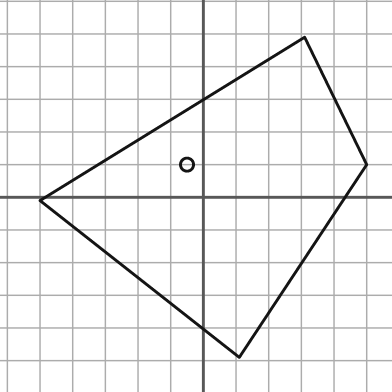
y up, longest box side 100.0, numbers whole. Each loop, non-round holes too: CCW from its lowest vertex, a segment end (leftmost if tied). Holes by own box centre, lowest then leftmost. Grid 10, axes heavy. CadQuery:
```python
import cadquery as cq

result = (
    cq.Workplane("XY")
    .moveTo(11.0, -49.0)
    .lineTo(50.0, 10.0)
    .lineTo(31.0, 49.0)
    .lineTo(-50.0, -1.0)
    .close()
    .moveTo(-5.0, 10.0)
    .circle(2.0)
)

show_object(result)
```